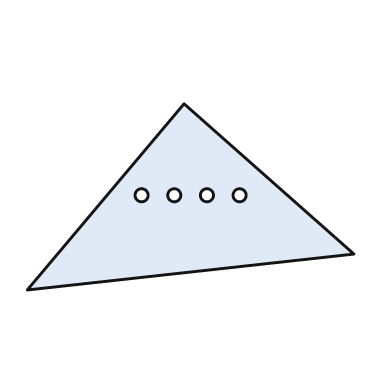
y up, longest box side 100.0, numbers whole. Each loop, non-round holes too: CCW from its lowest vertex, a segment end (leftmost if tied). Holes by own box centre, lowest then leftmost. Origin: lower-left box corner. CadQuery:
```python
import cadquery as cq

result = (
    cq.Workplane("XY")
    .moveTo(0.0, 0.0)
    .lineTo(100.0, 11.0)
    .lineTo(48.0, 57.0)
    .close()
    .moveTo(35.0, 29.0)
    .circle(2.0)
    .moveTo(45.0, 29.0)
    .circle(2.0)
    .moveTo(55.0, 29.0)
    .circle(2.0)
    .moveTo(65.0, 29.0)
    .circle(2.0)
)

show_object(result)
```